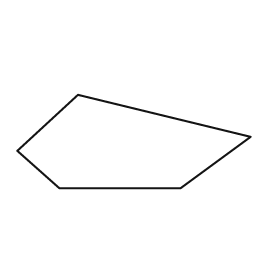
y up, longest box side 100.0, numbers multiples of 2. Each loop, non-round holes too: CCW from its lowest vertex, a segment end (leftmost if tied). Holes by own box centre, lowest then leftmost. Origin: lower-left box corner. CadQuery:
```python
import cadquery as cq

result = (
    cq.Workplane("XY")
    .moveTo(18.0, 0.0)
    .lineTo(70.0, 0.0)
    .lineTo(100.0, 22.0)
    .lineTo(26.0, 40.0)
    .lineTo(0.0, 16.0)
    .close()
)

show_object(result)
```